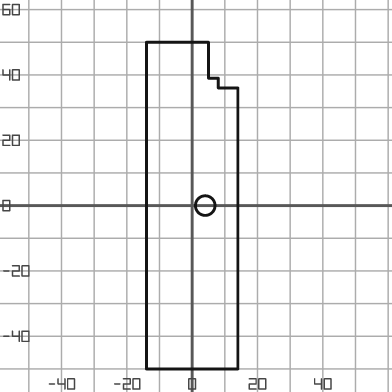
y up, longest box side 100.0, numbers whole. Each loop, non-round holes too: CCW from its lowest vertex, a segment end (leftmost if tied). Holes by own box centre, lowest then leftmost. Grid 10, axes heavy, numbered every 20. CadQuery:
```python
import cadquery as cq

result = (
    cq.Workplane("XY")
    .moveTo(-14.0, -50.0)
    .lineTo(14.0, -50.0)
    .lineTo(14.0, 36.0)
    .lineTo(8.0, 36.0)
    .lineTo(8.0, 39.0)
    .lineTo(5.0, 39.0)
    .lineTo(5.0, 50.0)
    .lineTo(-14.0, 50.0)
    .close()
    .moveTo(4.0, 0.0)
    .circle(3.0)
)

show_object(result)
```